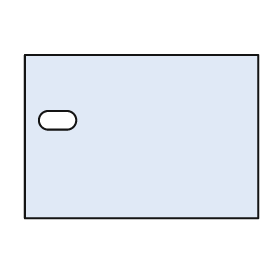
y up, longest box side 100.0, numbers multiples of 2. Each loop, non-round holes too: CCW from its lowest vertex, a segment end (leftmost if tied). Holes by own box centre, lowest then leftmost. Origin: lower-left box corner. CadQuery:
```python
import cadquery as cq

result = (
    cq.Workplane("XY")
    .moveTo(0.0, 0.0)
    .lineTo(100.0, 0.0)
    .lineTo(100.0, 70.0)
    .lineTo(0.0, 70.0)
    .close()
    .moveTo(10.0, 38.0)
    .lineTo(18.0, 38.0)
    .threePointArc((22.0, 42.0), (18.0, 46.0))
    .lineTo(10.0, 46.0)
    .threePointArc((6.0, 42.0), (10.0, 38.0))
    .close()
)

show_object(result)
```